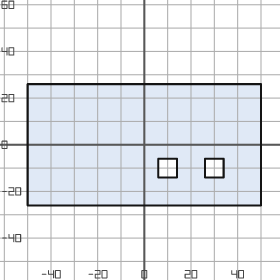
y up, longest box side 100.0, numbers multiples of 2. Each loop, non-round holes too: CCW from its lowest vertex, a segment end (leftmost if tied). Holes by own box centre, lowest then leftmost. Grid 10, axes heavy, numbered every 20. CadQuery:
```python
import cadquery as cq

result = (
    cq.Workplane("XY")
    .moveTo(-50.0, -26.0)
    .lineTo(50.0, -26.0)
    .lineTo(50.0, 26.0)
    .lineTo(-50.0, 26.0)
    .close()
    .moveTo(6.0, -14.0)
    .lineTo(14.0, -14.0)
    .lineTo(14.0, -6.0)
    .lineTo(6.0, -6.0)
    .close()
    .moveTo(26.0, -14.0)
    .lineTo(34.0, -14.0)
    .lineTo(34.0, -6.0)
    .lineTo(26.0, -6.0)
    .close()
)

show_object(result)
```